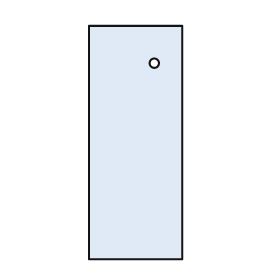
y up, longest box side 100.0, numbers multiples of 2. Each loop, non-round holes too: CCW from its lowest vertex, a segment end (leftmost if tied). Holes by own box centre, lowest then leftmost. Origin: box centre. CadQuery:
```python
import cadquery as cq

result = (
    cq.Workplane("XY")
    .moveTo(-20.0, -50.0)
    .lineTo(20.0, -50.0)
    .lineTo(20.0, 50.0)
    .lineTo(-20.0, 50.0)
    .close()
    .moveTo(8.0, 34.0)
    .circle(2.0)
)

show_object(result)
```